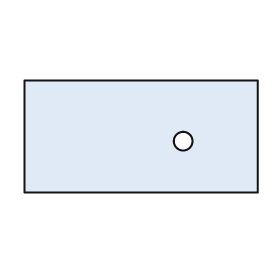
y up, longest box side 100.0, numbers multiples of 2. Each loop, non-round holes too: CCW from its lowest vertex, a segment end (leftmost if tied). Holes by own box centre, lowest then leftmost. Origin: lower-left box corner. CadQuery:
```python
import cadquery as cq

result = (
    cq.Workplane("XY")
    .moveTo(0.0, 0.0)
    .lineTo(100.0, 0.0)
    .lineTo(100.0, 48.0)
    .lineTo(0.0, 48.0)
    .close()
    .moveTo(68.0, 22.0)
    .circle(4.0)
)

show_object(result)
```